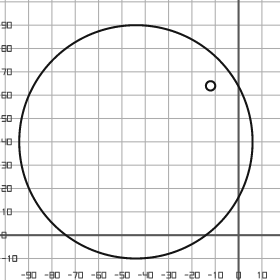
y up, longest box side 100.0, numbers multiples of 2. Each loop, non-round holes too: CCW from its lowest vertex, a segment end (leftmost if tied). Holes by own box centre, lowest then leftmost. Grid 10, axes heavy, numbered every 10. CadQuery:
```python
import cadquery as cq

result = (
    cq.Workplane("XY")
    .moveTo(-44.0, 40.0)
    .circle(50.0)
    .moveTo(-12.0, 64.0)
    .circle(2.0)
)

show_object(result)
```